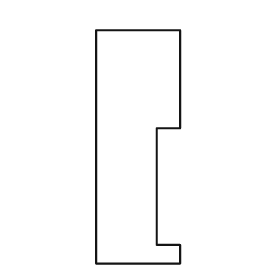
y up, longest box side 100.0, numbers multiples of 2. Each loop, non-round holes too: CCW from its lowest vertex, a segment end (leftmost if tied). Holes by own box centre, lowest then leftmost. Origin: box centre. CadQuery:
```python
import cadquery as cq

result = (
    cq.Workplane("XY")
    .moveTo(-18.0, -50.0)
    .lineTo(18.0, -50.0)
    .lineTo(18.0, -42.0)
    .lineTo(8.0, -42.0)
    .lineTo(8.0, 8.0)
    .lineTo(18.0, 8.0)
    .lineTo(18.0, 50.0)
    .lineTo(-18.0, 50.0)
    .close()
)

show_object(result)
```